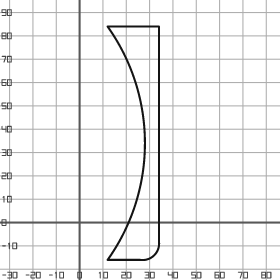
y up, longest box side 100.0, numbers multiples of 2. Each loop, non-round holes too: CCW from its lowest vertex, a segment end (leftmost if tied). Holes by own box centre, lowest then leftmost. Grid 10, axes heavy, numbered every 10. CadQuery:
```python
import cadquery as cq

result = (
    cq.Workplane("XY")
    .moveTo(12.0, -16.0)
    .lineTo(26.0, -16.0)
    .threePointArc((32.0, -14.0), (34.0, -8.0))
    .lineTo(34.0, 84.0)
    .lineTo(12.0, 84.0)
    .threePointArc((28.0, 34.0), (12.0, -16.0))
    .close()
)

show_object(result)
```